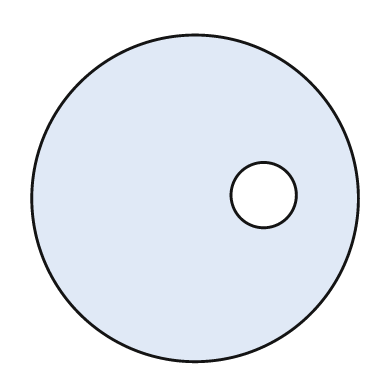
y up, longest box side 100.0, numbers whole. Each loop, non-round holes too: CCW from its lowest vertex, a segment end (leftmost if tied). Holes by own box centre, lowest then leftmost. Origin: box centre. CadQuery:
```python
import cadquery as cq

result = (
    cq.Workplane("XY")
    .moveTo(0.0, 0.0)
    .circle(50.0)
    .moveTo(21.0, 1.0)
    .circle(10.0)
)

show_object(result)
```